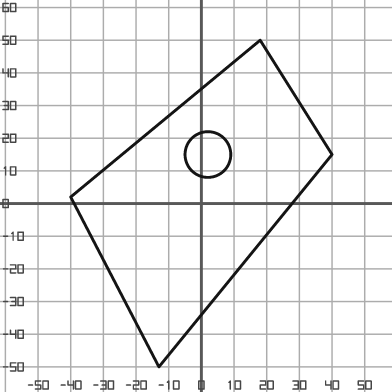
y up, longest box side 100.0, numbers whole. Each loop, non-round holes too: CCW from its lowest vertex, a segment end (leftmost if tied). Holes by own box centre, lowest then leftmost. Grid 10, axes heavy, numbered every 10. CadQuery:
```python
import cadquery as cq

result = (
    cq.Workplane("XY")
    .moveTo(-13.0, -50.0)
    .lineTo(40.0, 15.0)
    .lineTo(18.0, 50.0)
    .lineTo(-40.0, 2.0)
    .close()
    .moveTo(2.0, 15.0)
    .circle(7.0)
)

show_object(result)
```